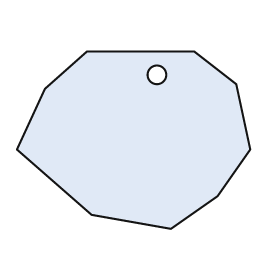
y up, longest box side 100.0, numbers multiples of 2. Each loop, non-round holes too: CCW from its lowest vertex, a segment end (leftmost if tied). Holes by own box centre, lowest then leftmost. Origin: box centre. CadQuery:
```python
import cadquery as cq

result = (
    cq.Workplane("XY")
    .moveTo(16.0, -38.0)
    .lineTo(36.0, -24.0)
    .lineTo(50.0, -4.0)
    .lineTo(44.0, 24.0)
    .lineTo(26.0, 38.0)
    .lineTo(-20.0, 38.0)
    .lineTo(-38.0, 22.0)
    .lineTo(-50.0, -4.0)
    .lineTo(-18.0, -32.0)
    .close()
    .moveTo(10.0, 28.0)
    .circle(4.0)
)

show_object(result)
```